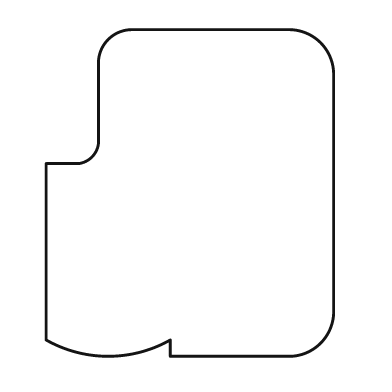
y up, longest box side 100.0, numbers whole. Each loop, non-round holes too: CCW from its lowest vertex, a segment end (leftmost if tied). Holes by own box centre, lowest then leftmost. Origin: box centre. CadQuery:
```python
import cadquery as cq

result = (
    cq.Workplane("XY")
    .moveTo(-6.0, -50.0)
    .lineTo(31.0, -50.0)
    .threePointArc((40.0, -46.0), (44.0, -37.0))
    .lineTo(44.0, 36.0)
    .threePointArc((40.0, 46.0), (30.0, 50.0))
    .lineTo(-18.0, 50.0)
    .threePointArc((-25.0, 47.0), (-28.0, 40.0))
    .lineTo(-28.0, 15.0)
    .threePointArc((-30.0, 11.0), (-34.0, 9.0))
    .lineTo(-44.0, 9.0)
    .lineTo(-44.0, -45.0)
    .threePointArc((-25.0, -50.0), (-6.0, -45.0))
    .close()
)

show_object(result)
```